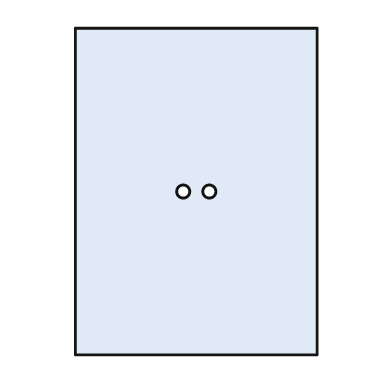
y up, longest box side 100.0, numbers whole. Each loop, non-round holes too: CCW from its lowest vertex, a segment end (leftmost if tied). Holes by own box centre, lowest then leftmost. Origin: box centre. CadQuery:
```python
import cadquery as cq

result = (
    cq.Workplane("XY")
    .moveTo(-37.0, -50.0)
    .lineTo(37.0, -50.0)
    .lineTo(37.0, 50.0)
    .lineTo(-37.0, 50.0)
    .close()
    .moveTo(-4.0, 0.0)
    .circle(2.0)
    .moveTo(4.0, 0.0)
    .circle(2.0)
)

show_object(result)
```